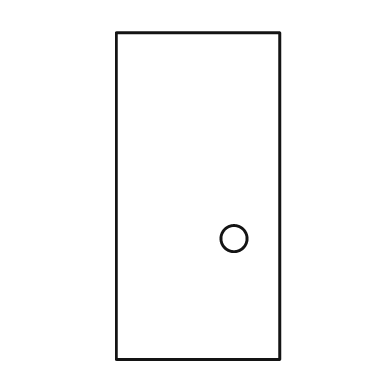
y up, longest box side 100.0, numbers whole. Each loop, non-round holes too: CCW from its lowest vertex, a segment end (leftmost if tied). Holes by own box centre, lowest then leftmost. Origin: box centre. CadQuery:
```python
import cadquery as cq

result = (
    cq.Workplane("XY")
    .moveTo(-25.0, -50.0)
    .lineTo(25.0, -50.0)
    .lineTo(25.0, 50.0)
    .lineTo(-25.0, 50.0)
    .close()
    .moveTo(11.0, -13.0)
    .circle(4.0)
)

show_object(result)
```